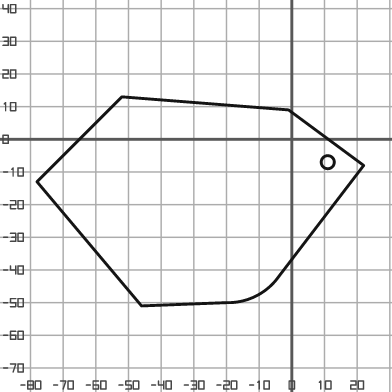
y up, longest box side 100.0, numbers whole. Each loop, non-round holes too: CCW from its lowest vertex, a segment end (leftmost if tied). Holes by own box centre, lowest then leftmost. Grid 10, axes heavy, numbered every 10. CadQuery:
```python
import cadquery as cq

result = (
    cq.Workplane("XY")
    .moveTo(-46.0, -51.0)
    .lineTo(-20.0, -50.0)
    .threePointArc((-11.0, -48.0), (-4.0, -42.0))
    .lineTo(22.0, -8.0)
    .lineTo(-1.0, 9.0)
    .lineTo(-52.0, 13.0)
    .lineTo(-78.0, -13.0)
    .close()
    .moveTo(11.0, -7.0)
    .circle(2.0)
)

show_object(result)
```